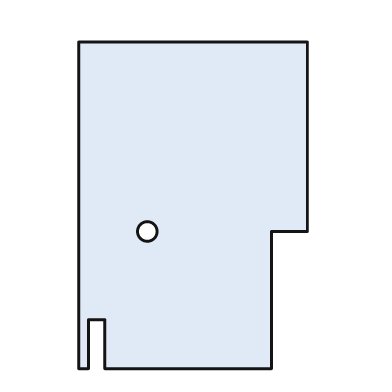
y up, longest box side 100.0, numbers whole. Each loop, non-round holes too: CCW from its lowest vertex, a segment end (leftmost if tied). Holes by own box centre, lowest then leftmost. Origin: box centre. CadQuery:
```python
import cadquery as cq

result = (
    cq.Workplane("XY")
    .moveTo(-35.0, -50.0)
    .lineTo(-32.0, -50.0)
    .lineTo(-32.0, -35.0)
    .lineTo(-27.0, -35.0)
    .lineTo(-27.0, -50.0)
    .lineTo(24.0, -50.0)
    .lineTo(24.0, -8.0)
    .lineTo(35.0, -8.0)
    .lineTo(35.0, 50.0)
    .lineTo(-35.0, 50.0)
    .close()
    .moveTo(-14.0, -8.0)
    .circle(3.0)
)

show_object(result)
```